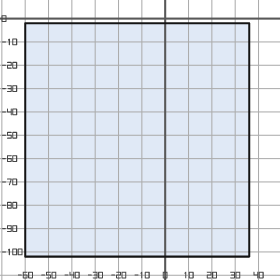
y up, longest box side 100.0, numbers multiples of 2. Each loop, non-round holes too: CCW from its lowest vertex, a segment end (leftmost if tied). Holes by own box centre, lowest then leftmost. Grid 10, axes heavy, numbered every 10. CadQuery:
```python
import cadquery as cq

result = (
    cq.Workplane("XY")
    .moveTo(-60.0, -102.0)
    .lineTo(36.0, -102.0)
    .lineTo(36.0, -2.0)
    .lineTo(-60.0, -2.0)
    .close()
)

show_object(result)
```